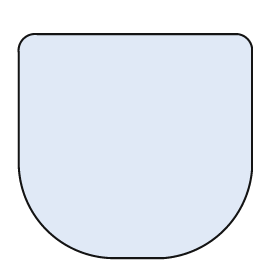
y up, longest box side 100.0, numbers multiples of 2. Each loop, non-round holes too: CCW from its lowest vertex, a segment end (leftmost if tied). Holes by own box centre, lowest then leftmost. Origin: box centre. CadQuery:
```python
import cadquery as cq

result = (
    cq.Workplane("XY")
    .moveTo(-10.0, -48.0)
    .lineTo(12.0, -48.0)
    .threePointArc((38.0, -36.0), (50.0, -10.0))
    .lineTo(50.0, 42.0)
    .threePointArc((48.0, 46.0), (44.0, 48.0))
    .lineTo(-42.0, 48.0)
    .threePointArc((-48.0, 46.0), (-50.0, 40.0))
    .lineTo(-50.0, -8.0)
    .threePointArc((-38.0, -36.0), (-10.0, -48.0))
    .close()
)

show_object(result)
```